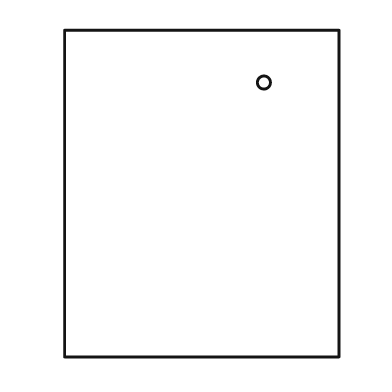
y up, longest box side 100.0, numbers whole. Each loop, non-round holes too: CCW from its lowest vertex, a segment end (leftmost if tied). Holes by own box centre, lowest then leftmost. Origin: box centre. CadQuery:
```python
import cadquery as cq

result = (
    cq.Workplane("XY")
    .moveTo(-42.0, -50.0)
    .lineTo(42.0, -50.0)
    .lineTo(42.0, 50.0)
    .lineTo(-42.0, 50.0)
    .close()
    .moveTo(19.0, 34.0)
    .circle(2.0)
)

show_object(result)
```